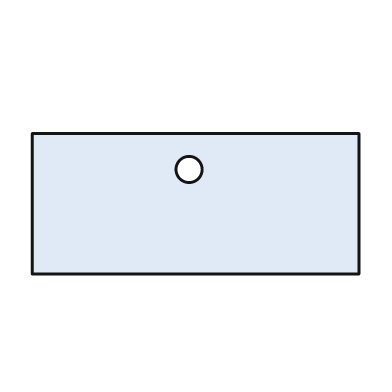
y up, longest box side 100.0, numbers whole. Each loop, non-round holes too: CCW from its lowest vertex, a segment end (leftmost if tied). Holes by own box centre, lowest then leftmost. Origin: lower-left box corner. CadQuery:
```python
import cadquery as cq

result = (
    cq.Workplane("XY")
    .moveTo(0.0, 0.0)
    .lineTo(100.0, 0.0)
    .lineTo(100.0, 43.0)
    .lineTo(0.0, 43.0)
    .close()
    .moveTo(48.0, 32.0)
    .circle(4.0)
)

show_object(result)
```